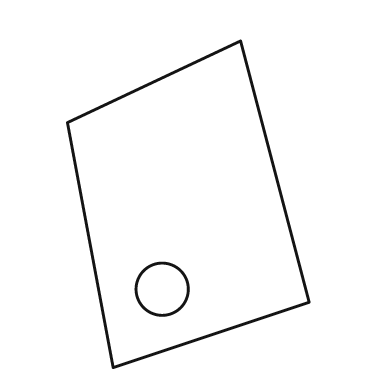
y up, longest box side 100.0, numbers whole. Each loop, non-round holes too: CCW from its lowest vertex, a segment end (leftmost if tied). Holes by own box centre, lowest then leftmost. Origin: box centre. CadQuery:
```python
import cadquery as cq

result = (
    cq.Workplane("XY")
    .moveTo(-23.0, -50.0)
    .lineTo(37.0, -30.0)
    .lineTo(16.0, 50.0)
    .lineTo(-37.0, 25.0)
    .close()
    .moveTo(-8.0, -26.0)
    .circle(8.0)
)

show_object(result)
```